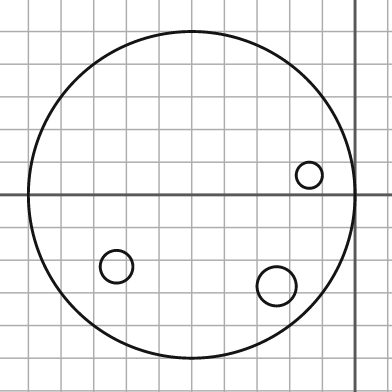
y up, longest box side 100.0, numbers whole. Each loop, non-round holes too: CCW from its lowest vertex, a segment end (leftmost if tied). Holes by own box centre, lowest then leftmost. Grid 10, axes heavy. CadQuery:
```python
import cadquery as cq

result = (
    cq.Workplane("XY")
    .moveTo(-50.0, 0.0)
    .circle(50.0)
    .moveTo(-24.0, -28.0)
    .circle(6.0)
    .moveTo(-73.0, -22.0)
    .circle(5.0)
    .moveTo(-14.0, 6.0)
    .circle(4.0)
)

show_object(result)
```